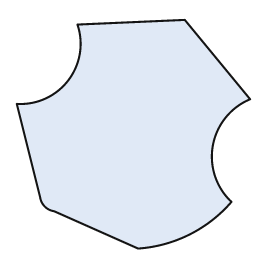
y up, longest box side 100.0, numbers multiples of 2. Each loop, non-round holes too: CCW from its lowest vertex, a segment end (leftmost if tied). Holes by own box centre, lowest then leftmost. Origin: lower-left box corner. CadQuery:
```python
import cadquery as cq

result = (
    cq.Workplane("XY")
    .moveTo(52.0, 0.0)
    .threePointArc((74.0, 6.0), (92.0, 20.0))
    .threePointArc((84.0, 44.0), (100.0, 64.0))
    .lineTo(72.0, 98.0)
    .lineTo(26.0, 96.0)
    .threePointArc((22.0, 72.0), (0.0, 62.0))
    .lineTo(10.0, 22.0)
    .threePointArc((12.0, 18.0), (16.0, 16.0))
    .close()
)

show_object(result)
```